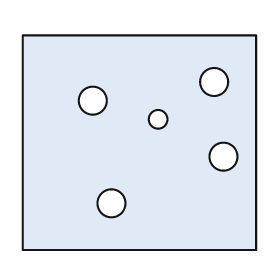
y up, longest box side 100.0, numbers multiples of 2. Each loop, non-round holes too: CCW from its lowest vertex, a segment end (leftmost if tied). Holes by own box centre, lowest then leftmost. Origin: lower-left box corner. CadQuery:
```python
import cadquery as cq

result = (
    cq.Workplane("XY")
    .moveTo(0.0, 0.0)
    .lineTo(100.0, 0.0)
    .lineTo(100.0, 92.0)
    .lineTo(0.0, 92.0)
    .close()
    .moveTo(38.0, 20.0)
    .circle(6.0)
    .moveTo(86.0, 40.0)
    .circle(6.0)
    .moveTo(58.0, 56.0)
    .circle(4.0)
    .moveTo(30.0, 64.0)
    .circle(6.0)
    .moveTo(82.0, 72.0)
    .circle(6.0)
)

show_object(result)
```